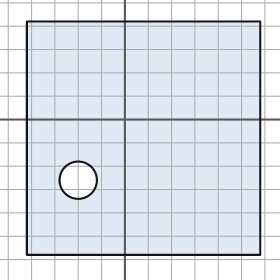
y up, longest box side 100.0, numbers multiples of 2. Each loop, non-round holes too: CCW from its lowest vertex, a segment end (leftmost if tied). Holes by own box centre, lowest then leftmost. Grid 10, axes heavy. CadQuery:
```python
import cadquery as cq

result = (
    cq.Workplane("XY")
    .moveTo(-42.0, -58.0)
    .lineTo(58.0, -58.0)
    .lineTo(58.0, 42.0)
    .lineTo(-42.0, 42.0)
    .close()
    .moveTo(-20.0, -26.0)
    .circle(8.0)
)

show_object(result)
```